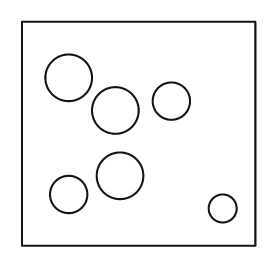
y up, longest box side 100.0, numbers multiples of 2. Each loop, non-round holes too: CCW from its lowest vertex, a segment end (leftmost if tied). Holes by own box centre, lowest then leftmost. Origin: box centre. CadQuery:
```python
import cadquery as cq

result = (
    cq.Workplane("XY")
    .moveTo(-50.0, -48.0)
    .lineTo(50.0, -48.0)
    .lineTo(50.0, 48.0)
    .lineTo(-50.0, 48.0)
    .close()
    .moveTo(36.0, -32.0)
    .circle(6.0)
    .moveTo(-30.0, -26.0)
    .circle(8.0)
    .moveTo(-8.0, -18.0)
    .circle(10.0)
    .moveTo(-10.0, 10.0)
    .circle(10.0)
    .moveTo(14.0, 14.0)
    .circle(8.0)
    .moveTo(-30.0, 24.0)
    .circle(10.0)
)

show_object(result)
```